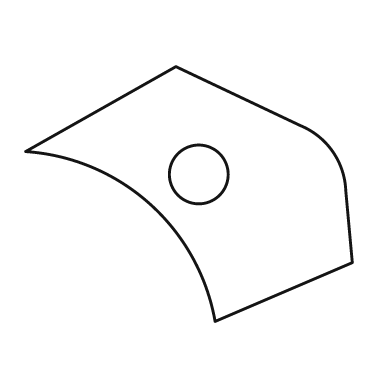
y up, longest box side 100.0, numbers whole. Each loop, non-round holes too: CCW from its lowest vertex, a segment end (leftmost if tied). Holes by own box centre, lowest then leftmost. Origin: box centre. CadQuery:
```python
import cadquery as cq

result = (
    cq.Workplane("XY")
    .moveTo(8.0, -39.0)
    .lineTo(50.0, -21.0)
    .lineTo(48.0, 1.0)
    .threePointArc((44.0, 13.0), (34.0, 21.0))
    .lineTo(-4.0, 39.0)
    .lineTo(-50.0, 13.0)
    .threePointArc((-12.0, -3.0), (8.0, -39.0))
    .close()
    .moveTo(3.0, 6.0)
    .circle(9.0)
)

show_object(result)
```